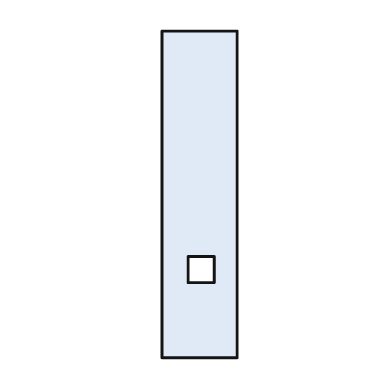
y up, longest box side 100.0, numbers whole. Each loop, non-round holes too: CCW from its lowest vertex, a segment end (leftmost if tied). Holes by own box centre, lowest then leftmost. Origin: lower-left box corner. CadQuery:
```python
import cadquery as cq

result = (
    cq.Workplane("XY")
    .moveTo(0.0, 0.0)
    .lineTo(23.0, 0.0)
    .lineTo(23.0, 100.0)
    .lineTo(0.0, 100.0)
    .close()
    .moveTo(8.0, 23.0)
    .lineTo(16.0, 23.0)
    .lineTo(16.0, 31.0)
    .lineTo(8.0, 31.0)
    .close()
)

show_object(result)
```